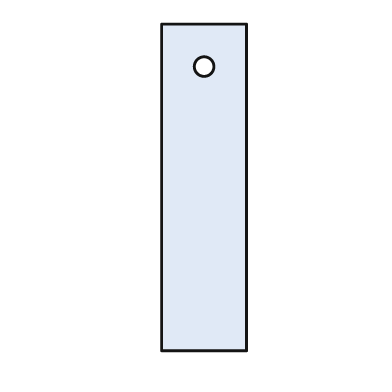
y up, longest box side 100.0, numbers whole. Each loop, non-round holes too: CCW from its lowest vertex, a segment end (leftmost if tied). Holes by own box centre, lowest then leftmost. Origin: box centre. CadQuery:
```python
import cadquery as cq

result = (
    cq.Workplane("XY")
    .moveTo(-13.0, -50.0)
    .lineTo(13.0, -50.0)
    .lineTo(13.0, 50.0)
    .lineTo(-13.0, 50.0)
    .close()
    .moveTo(0.0, 37.0)
    .circle(3.0)
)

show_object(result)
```